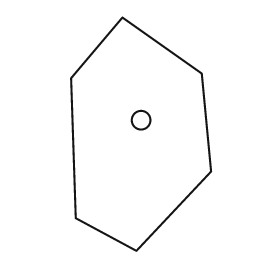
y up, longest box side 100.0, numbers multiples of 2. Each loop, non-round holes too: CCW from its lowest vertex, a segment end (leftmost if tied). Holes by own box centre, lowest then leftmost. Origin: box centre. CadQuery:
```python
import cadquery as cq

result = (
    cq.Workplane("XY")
    .moveTo(-2.0, -50.0)
    .lineTo(30.0, -16.0)
    .lineTo(26.0, 26.0)
    .lineTo(-8.0, 50.0)
    .lineTo(-30.0, 24.0)
    .lineTo(-28.0, -36.0)
    .close()
    .moveTo(0.0, 6.0)
    .circle(4.0)
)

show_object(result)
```